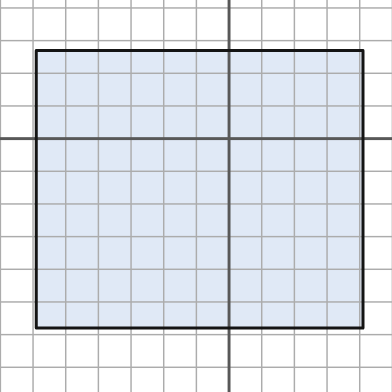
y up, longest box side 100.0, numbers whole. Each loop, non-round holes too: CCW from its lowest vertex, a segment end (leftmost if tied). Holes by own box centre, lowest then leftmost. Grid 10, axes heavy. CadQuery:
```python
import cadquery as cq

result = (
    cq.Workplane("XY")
    .moveTo(-59.0, -58.0)
    .lineTo(41.0, -58.0)
    .lineTo(41.0, 27.0)
    .lineTo(-59.0, 27.0)
    .close()
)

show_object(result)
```